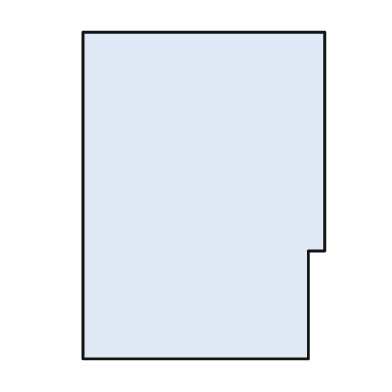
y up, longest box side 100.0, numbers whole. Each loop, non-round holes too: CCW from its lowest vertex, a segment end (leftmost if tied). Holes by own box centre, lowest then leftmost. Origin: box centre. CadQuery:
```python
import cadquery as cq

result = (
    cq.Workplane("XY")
    .moveTo(-37.0, -50.0)
    .lineTo(32.0, -50.0)
    .lineTo(32.0, -17.0)
    .lineTo(37.0, -17.0)
    .lineTo(37.0, 50.0)
    .lineTo(-37.0, 50.0)
    .close()
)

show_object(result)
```